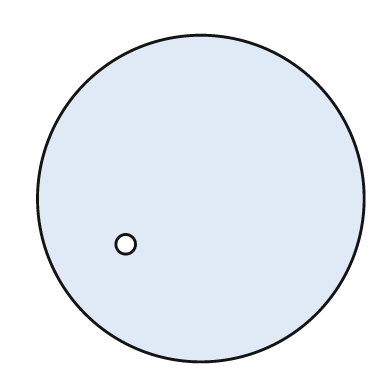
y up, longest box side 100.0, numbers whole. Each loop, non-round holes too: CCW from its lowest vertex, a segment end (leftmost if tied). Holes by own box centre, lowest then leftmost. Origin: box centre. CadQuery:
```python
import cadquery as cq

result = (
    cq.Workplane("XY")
    .moveTo(0.0, 0.0)
    .circle(50.0)
    .moveTo(-23.0, -14.0)
    .circle(3.0)
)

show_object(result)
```